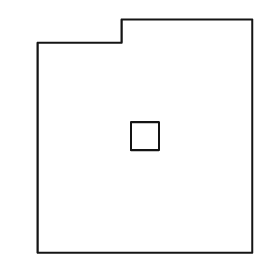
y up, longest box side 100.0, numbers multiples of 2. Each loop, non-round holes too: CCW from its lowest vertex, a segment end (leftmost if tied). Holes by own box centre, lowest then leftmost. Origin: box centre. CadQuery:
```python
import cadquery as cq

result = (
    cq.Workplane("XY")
    .moveTo(-46.0, -50.0)
    .lineTo(46.0, -50.0)
    .lineTo(46.0, 50.0)
    .lineTo(-10.0, 50.0)
    .lineTo(-10.0, 40.0)
    .lineTo(-46.0, 40.0)
    .close()
    .moveTo(-6.0, -6.0)
    .lineTo(6.0, -6.0)
    .lineTo(6.0, 6.0)
    .lineTo(-6.0, 6.0)
    .close()
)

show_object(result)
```